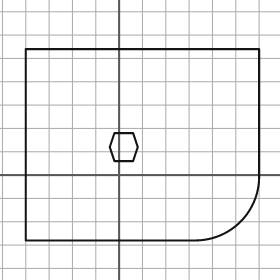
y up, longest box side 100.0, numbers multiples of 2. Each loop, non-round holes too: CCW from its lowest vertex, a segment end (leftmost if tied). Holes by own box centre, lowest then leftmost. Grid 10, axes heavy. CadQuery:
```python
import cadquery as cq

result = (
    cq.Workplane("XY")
    .moveTo(-40.0, -28.0)
    .lineTo(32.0, -28.0)
    .threePointArc((52.0, -20.0), (60.0, 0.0))
    .lineTo(60.0, 54.0)
    .lineTo(-40.0, 54.0)
    .close()
    .moveTo(-2.0, 6.0)
    .lineTo(6.0, 6.0)
    .lineTo(8.0, 12.0)
    .lineTo(6.0, 18.0)
    .lineTo(-2.0, 18.0)
    .lineTo(-4.0, 12.0)
    .close()
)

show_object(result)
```